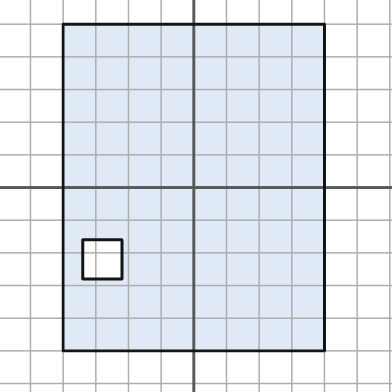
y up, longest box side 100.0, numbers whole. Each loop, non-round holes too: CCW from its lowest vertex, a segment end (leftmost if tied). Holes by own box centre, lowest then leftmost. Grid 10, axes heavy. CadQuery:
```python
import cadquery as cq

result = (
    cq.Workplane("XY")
    .moveTo(-40.0, -50.0)
    .lineTo(40.0, -50.0)
    .lineTo(40.0, 50.0)
    .lineTo(-40.0, 50.0)
    .close()
    .moveTo(-34.0, -28.0)
    .lineTo(-22.0, -28.0)
    .lineTo(-22.0, -16.0)
    .lineTo(-34.0, -16.0)
    .close()
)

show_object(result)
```